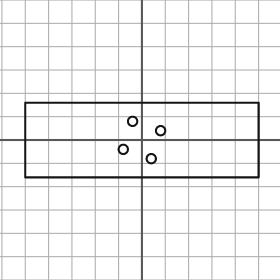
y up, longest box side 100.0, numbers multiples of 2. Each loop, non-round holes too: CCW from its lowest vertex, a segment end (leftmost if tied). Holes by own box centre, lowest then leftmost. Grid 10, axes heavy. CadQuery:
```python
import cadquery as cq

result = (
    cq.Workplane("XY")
    .moveTo(-50.0, -16.0)
    .lineTo(50.0, -16.0)
    .lineTo(50.0, 16.0)
    .lineTo(-50.0, 16.0)
    .close()
    .moveTo(4.0, -8.0)
    .circle(2.0)
    .moveTo(-8.0, -4.0)
    .circle(2.0)
    .moveTo(8.0, 4.0)
    .circle(2.0)
    .moveTo(-4.0, 8.0)
    .circle(2.0)
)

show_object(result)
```